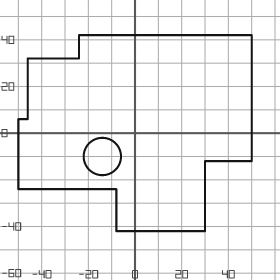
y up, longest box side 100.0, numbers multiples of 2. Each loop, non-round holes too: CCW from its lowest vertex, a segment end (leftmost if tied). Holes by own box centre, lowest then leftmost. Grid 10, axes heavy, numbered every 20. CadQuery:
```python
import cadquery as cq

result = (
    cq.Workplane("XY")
    .moveTo(-8.0, -42.0)
    .lineTo(30.0, -42.0)
    .lineTo(30.0, -12.0)
    .lineTo(50.0, -12.0)
    .lineTo(50.0, 42.0)
    .lineTo(-24.0, 42.0)
    .lineTo(-24.0, 32.0)
    .lineTo(-46.0, 32.0)
    .lineTo(-46.0, 6.0)
    .lineTo(-50.0, 6.0)
    .lineTo(-50.0, -24.0)
    .lineTo(-8.0, -24.0)
    .close()
    .moveTo(-14.0, -10.0)
    .circle(8.0)
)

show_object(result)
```